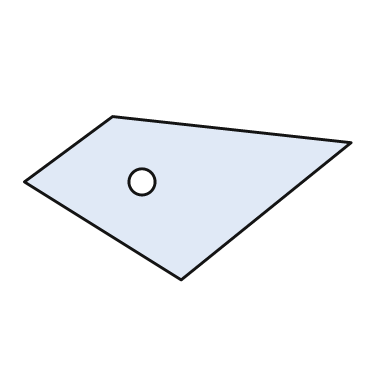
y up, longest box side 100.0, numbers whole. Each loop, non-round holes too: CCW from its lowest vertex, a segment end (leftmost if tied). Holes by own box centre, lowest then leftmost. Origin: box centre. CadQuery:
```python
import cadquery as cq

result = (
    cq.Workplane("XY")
    .moveTo(-2.0, -25.0)
    .lineTo(50.0, 17.0)
    .lineTo(-23.0, 25.0)
    .lineTo(-50.0, 5.0)
    .close()
    .moveTo(-14.0, 5.0)
    .circle(4.0)
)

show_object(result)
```